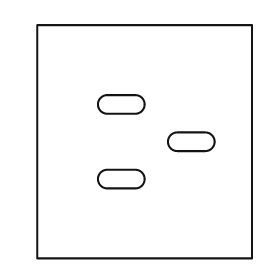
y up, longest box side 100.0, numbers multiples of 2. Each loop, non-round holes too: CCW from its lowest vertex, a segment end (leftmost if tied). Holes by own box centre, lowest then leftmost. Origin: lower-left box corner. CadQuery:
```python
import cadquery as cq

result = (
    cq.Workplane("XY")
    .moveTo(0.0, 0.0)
    .lineTo(92.0, 0.0)
    .lineTo(92.0, 100.0)
    .lineTo(0.0, 100.0)
    .close()
    .moveTo(30.0, 30.0)
    .lineTo(42.0, 30.0)
    .threePointArc((46.0, 34.0), (42.0, 38.0))
    .lineTo(30.0, 38.0)
    .threePointArc((26.0, 34.0), (30.0, 30.0))
    .close()
    .moveTo(60.0, 46.0)
    .lineTo(72.0, 46.0)
    .threePointArc((76.0, 50.0), (72.0, 54.0))
    .lineTo(60.0, 54.0)
    .threePointArc((56.0, 50.0), (60.0, 46.0))
    .close()
    .moveTo(30.0, 62.0)
    .lineTo(42.0, 62.0)
    .threePointArc((46.0, 66.0), (42.0, 70.0))
    .lineTo(30.0, 70.0)
    .threePointArc((26.0, 66.0), (30.0, 62.0))
    .close()
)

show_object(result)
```